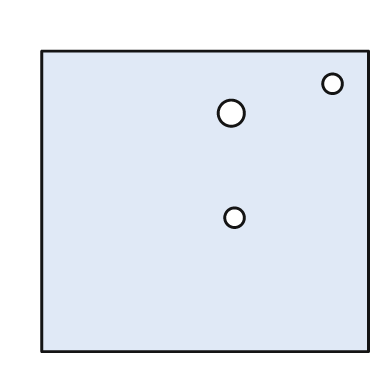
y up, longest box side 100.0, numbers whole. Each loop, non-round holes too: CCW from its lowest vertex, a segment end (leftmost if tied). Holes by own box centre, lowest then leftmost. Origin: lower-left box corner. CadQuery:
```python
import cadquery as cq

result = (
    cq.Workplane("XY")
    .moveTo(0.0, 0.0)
    .lineTo(100.0, 0.0)
    .lineTo(100.0, 92.0)
    .lineTo(0.0, 92.0)
    .close()
    .moveTo(59.0, 41.0)
    .circle(3.0)
    .moveTo(58.0, 73.0)
    .circle(4.0)
    .moveTo(89.0, 82.0)
    .circle(3.0)
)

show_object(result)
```